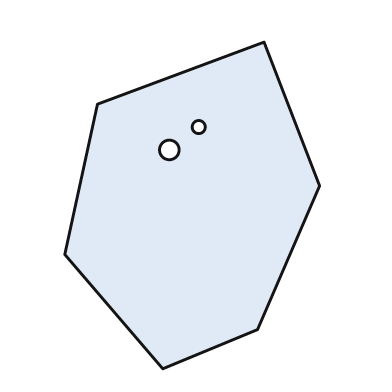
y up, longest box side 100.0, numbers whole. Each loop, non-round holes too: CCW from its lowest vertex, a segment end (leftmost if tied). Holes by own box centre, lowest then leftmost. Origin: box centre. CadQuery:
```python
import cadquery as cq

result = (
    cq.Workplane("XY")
    .moveTo(-9.0, -50.0)
    .lineTo(20.0, -38.0)
    .lineTo(39.0, 6.0)
    .lineTo(22.0, 50.0)
    .lineTo(-29.0, 31.0)
    .lineTo(-39.0, -15.0)
    .close()
    .moveTo(-7.0, 17.0)
    .circle(3.0)
    .moveTo(2.0, 24.0)
    .circle(2.0)
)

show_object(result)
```